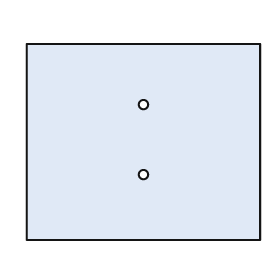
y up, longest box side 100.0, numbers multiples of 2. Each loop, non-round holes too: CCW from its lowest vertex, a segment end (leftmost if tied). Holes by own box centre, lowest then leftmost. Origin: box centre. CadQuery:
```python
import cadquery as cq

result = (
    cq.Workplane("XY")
    .moveTo(-50.0, -42.0)
    .lineTo(50.0, -42.0)
    .lineTo(50.0, 42.0)
    .lineTo(-50.0, 42.0)
    .close()
    .moveTo(0.0, -14.0)
    .circle(2.0)
    .moveTo(0.0, 16.0)
    .circle(2.0)
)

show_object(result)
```